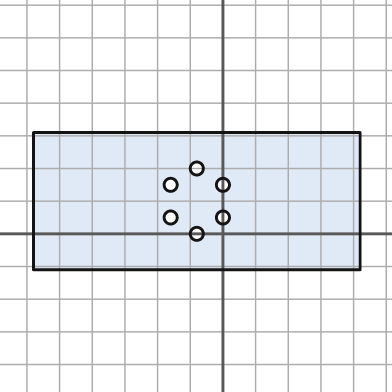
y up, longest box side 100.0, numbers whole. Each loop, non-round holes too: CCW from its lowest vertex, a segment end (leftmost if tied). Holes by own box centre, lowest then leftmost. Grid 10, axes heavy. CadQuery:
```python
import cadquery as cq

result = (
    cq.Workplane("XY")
    .moveTo(-58.0, -11.0)
    .lineTo(42.0, -11.0)
    .lineTo(42.0, 31.0)
    .lineTo(-58.0, 31.0)
    .close()
    .moveTo(-8.0, 0.0)
    .circle(2.0)
    .moveTo(-16.0, 5.0)
    .circle(2.0)
    .moveTo(0.0, 5.0)
    .circle(2.0)
    .moveTo(-16.0, 15.0)
    .circle(2.0)
    .moveTo(0.0, 15.0)
    .circle(2.0)
    .moveTo(-8.0, 20.0)
    .circle(2.0)
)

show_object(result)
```